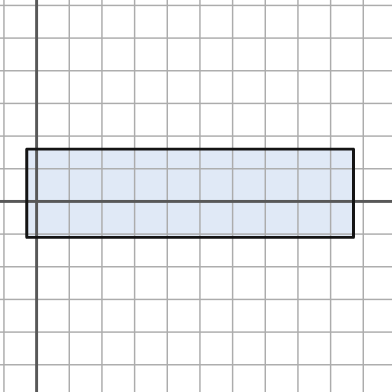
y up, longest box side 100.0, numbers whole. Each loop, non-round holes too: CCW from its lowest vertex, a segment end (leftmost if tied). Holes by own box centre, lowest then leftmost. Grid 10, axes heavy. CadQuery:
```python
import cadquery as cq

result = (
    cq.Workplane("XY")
    .moveTo(-3.0, -11.0)
    .lineTo(97.0, -11.0)
    .lineTo(97.0, 16.0)
    .lineTo(-3.0, 16.0)
    .close()
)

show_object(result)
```